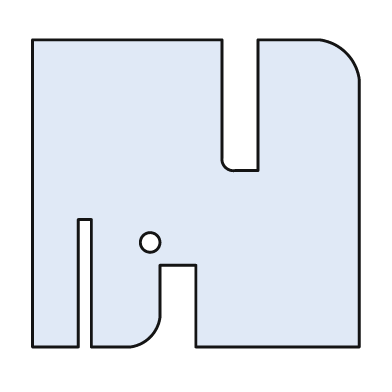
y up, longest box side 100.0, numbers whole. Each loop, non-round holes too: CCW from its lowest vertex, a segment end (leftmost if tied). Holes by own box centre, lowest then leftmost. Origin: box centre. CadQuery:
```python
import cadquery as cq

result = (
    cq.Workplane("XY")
    .moveTo(-50.0, -47.0)
    .lineTo(-36.0, -47.0)
    .lineTo(-36.0, -8.0)
    .lineTo(-32.0, -8.0)
    .lineTo(-32.0, -47.0)
    .lineTo(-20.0, -47.0)
    .threePointArc((-14.0, -44.0), (-11.0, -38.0))
    .lineTo(-11.0, -22.0)
    .lineTo(0.0, -22.0)
    .lineTo(0.0, -47.0)
    .lineTo(50.0, -47.0)
    .lineTo(50.0, 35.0)
    .threePointArc((46.0, 43.0), (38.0, 47.0))
    .lineTo(19.0, 47.0)
    .lineTo(19.0, 7.0)
    .lineTo(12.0, 7.0)
    .threePointArc((9.0, 8.0), (8.0, 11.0))
    .lineTo(8.0, 47.0)
    .lineTo(-50.0, 47.0)
    .close()
    .moveTo(-14.0, -15.0)
    .circle(3.0)
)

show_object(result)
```